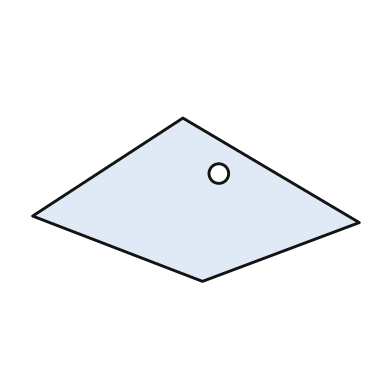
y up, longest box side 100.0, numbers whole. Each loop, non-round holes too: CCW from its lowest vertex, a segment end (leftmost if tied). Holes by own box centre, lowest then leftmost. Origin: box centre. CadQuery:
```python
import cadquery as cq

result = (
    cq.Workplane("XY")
    .moveTo(2.0, -25.0)
    .lineTo(50.0, -7.0)
    .lineTo(-4.0, 25.0)
    .lineTo(-50.0, -5.0)
    .close()
    .moveTo(7.0, 8.0)
    .circle(3.0)
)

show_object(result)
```